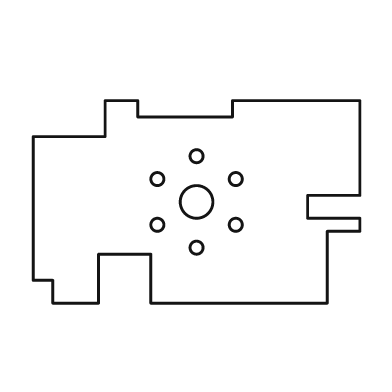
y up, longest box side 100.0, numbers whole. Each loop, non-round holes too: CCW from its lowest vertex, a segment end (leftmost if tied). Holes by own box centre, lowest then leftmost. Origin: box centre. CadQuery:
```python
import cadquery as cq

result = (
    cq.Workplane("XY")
    .moveTo(-44.0, -31.0)
    .lineTo(-30.0, -31.0)
    .lineTo(-30.0, -16.0)
    .lineTo(-14.0, -16.0)
    .lineTo(-14.0, -31.0)
    .lineTo(40.0, -31.0)
    .lineTo(40.0, -9.0)
    .lineTo(50.0, -9.0)
    .lineTo(50.0, -5.0)
    .lineTo(34.0, -5.0)
    .lineTo(34.0, 2.0)
    .lineTo(50.0, 2.0)
    .lineTo(50.0, 31.0)
    .lineTo(11.0, 31.0)
    .lineTo(11.0, 26.0)
    .lineTo(-18.0, 26.0)
    .lineTo(-18.0, 31.0)
    .lineTo(-28.0, 31.0)
    .lineTo(-28.0, 20.0)
    .lineTo(-50.0, 20.0)
    .lineTo(-50.0, -24.0)
    .lineTo(-44.0, -24.0)
    .close()
    .moveTo(0.0, -14.0)
    .circle(2.0)
    .moveTo(-12.0, -7.0)
    .circle(2.0)
    .moveTo(12.0, -7.0)
    .circle(2.0)
    .moveTo(0.0, 0.0)
    .circle(5.0)
    .moveTo(-12.0, 7.0)
    .circle(2.0)
    .moveTo(12.0, 7.0)
    .circle(2.0)
    .moveTo(0.0, 14.0)
    .circle(2.0)
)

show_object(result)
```